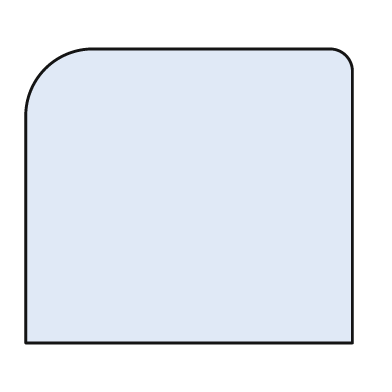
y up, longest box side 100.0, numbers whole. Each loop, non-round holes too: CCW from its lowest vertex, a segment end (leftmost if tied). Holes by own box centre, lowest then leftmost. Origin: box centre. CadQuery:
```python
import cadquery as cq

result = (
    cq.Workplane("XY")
    .moveTo(-50.0, -45.0)
    .lineTo(50.0, -45.0)
    .lineTo(50.0, 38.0)
    .threePointArc((48.0, 43.0), (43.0, 45.0))
    .lineTo(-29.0, 45.0)
    .threePointArc((-44.0, 39.0), (-50.0, 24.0))
    .close()
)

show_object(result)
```